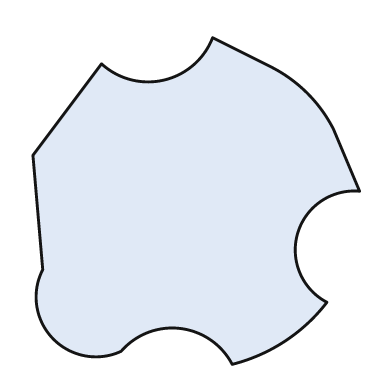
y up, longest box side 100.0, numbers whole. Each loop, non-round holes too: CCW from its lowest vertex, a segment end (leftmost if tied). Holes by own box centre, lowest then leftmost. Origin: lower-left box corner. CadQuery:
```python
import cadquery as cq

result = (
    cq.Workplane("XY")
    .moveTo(61.0, 0.0)
    .threePointArc((77.0, 7.0), (90.0, 19.0))
    .threePointArc((81.0, 40.0), (100.0, 53.0))
    .lineTo(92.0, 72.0)
    .threePointArc((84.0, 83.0), (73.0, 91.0))
    .lineTo(55.0, 100.0)
    .threePointArc((40.0, 87.0), (21.0, 92.0))
    .lineTo(0.0, 64.0)
    .lineTo(3.0, 29.0)
    .threePointArc((6.0, 8.0), (27.0, 4.0))
    .threePointArc((45.0, 11.0), (61.0, 0.0))
    .close()
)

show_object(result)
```